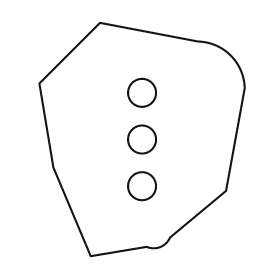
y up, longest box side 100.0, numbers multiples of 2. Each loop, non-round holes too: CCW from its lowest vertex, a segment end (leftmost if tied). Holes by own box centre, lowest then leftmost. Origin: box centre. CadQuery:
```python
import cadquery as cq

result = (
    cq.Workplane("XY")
    .moveTo(-22.0, -50.0)
    .lineTo(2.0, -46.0)
    .threePointArc((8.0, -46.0), (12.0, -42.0))
    .lineTo(36.0, -22.0)
    .lineTo(44.0, 22.0)
    .threePointArc((38.0, 36.0), (24.0, 42.0))
    .lineTo(-18.0, 50.0)
    .lineTo(-44.0, 24.0)
    .lineTo(-38.0, -12.0)
    .close()
    .moveTo(0.0, -20.0)
    .circle(6.0)
    .moveTo(0.0, 0.0)
    .circle(6.0)
    .moveTo(0.0, 20.0)
    .circle(6.0)
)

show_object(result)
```